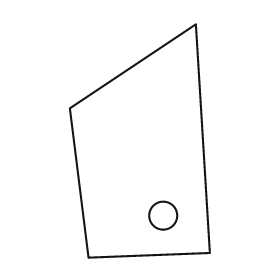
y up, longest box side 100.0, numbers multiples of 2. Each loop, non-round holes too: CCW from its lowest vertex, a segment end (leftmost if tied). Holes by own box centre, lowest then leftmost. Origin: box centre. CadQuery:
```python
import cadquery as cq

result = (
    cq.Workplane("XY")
    .moveTo(-22.0, -50.0)
    .lineTo(30.0, -48.0)
    .lineTo(24.0, 50.0)
    .lineTo(-30.0, 14.0)
    .close()
    .moveTo(10.0, -32.0)
    .circle(6.0)
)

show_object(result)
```